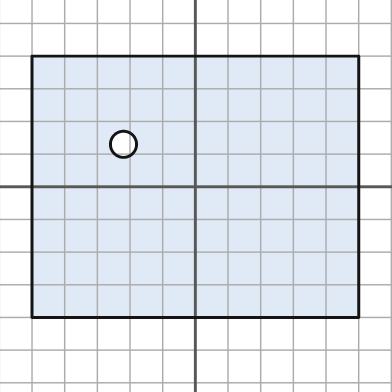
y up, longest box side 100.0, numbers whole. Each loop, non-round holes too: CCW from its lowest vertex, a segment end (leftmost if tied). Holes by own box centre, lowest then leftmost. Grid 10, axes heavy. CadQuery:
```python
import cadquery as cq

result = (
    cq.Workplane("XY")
    .moveTo(-50.0, -40.0)
    .lineTo(50.0, -40.0)
    .lineTo(50.0, 40.0)
    .lineTo(-50.0, 40.0)
    .close()
    .moveTo(-22.0, 13.0)
    .circle(4.0)
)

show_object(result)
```